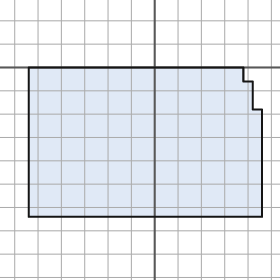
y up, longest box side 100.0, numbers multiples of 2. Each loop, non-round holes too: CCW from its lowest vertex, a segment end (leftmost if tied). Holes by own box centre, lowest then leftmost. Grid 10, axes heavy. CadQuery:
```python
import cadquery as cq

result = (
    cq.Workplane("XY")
    .moveTo(-54.0, -64.0)
    .lineTo(46.0, -64.0)
    .lineTo(46.0, -18.0)
    .lineTo(42.0, -18.0)
    .lineTo(42.0, -6.0)
    .lineTo(38.0, -6.0)
    .lineTo(38.0, 0.0)
    .lineTo(-54.0, 0.0)
    .close()
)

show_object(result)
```